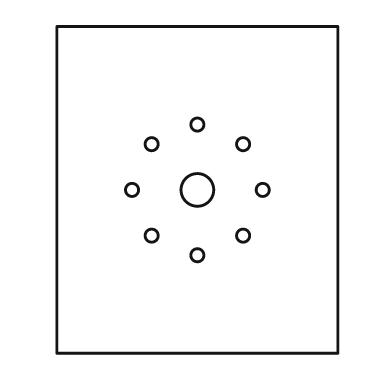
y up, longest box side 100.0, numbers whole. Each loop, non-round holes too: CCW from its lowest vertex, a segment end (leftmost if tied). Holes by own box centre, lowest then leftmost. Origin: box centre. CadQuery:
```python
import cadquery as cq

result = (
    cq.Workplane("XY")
    .moveTo(-43.0, -50.0)
    .lineTo(43.0, -50.0)
    .lineTo(43.0, 50.0)
    .lineTo(-43.0, 50.0)
    .close()
    .moveTo(0.0, -20.0)
    .circle(2.0)
    .moveTo(-14.0, -14.0)
    .circle(2.0)
    .moveTo(14.0, -14.0)
    .circle(2.0)
    .moveTo(-20.0, 0.0)
    .circle(2.0)
    .moveTo(0.0, 0.0)
    .circle(5.0)
    .moveTo(20.0, 0.0)
    .circle(2.0)
    .moveTo(-14.0, 14.0)
    .circle(2.0)
    .moveTo(14.0, 14.0)
    .circle(2.0)
    .moveTo(0.0, 20.0)
    .circle(2.0)
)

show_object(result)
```